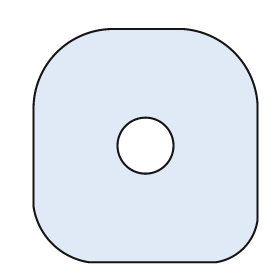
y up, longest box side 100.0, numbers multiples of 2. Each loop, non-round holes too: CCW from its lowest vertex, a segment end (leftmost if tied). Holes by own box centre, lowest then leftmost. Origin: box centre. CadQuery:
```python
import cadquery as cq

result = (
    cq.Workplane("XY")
    .moveTo(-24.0, -50.0)
    .lineTo(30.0, -50.0)
    .threePointArc((42.0, -44.0), (48.0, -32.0))
    .lineTo(48.0, 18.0)
    .threePointArc((38.0, 40.0), (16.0, 50.0))
    .lineTo(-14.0, 50.0)
    .threePointArc((-38.0, 40.0), (-48.0, 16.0))
    .lineTo(-48.0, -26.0)
    .threePointArc((-40.0, -42.0), (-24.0, -50.0))
    .close()
    .moveTo(0.0, 0.0)
    .circle(12.0)
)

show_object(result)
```